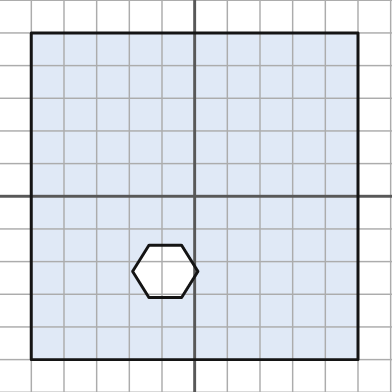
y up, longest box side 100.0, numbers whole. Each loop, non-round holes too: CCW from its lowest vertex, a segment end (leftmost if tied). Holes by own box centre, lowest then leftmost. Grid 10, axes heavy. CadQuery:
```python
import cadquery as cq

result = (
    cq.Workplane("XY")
    .moveTo(-50.0, -50.0)
    .lineTo(50.0, -50.0)
    .lineTo(50.0, 50.0)
    .lineTo(-50.0, 50.0)
    .close()
    .moveTo(-14.0, -31.0)
    .lineTo(-4.0, -31.0)
    .lineTo(1.0, -23.0)
    .lineTo(-4.0, -15.0)
    .lineTo(-14.0, -15.0)
    .lineTo(-19.0, -23.0)
    .close()
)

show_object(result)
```